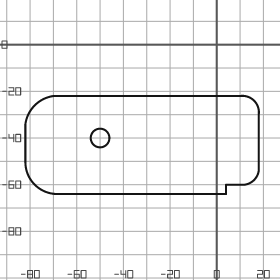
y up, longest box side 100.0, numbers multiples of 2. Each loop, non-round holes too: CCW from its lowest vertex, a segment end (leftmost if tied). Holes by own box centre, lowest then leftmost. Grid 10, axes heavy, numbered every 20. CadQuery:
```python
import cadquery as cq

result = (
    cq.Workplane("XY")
    .moveTo(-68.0, -64.0)
    .lineTo(4.0, -64.0)
    .lineTo(4.0, -60.0)
    .lineTo(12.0, -60.0)
    .threePointArc((16.0, -58.0), (18.0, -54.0))
    .lineTo(18.0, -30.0)
    .threePointArc((16.0, -24.0), (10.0, -22.0))
    .lineTo(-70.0, -22.0)
    .threePointArc((-78.0, -26.0), (-82.0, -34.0))
    .lineTo(-82.0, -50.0)
    .threePointArc((-78.0, -60.0), (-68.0, -64.0))
    .close()
    .moveTo(-50.0, -40.0)
    .circle(4.0)
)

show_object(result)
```